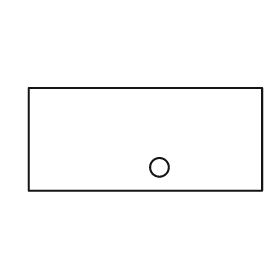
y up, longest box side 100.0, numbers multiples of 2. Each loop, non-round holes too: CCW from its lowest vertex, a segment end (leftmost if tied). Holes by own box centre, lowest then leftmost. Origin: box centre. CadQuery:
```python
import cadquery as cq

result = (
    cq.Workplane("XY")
    .moveTo(-50.0, -22.0)
    .lineTo(50.0, -22.0)
    .lineTo(50.0, 22.0)
    .lineTo(-50.0, 22.0)
    .close()
    .moveTo(6.0, -12.0)
    .circle(4.0)
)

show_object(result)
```